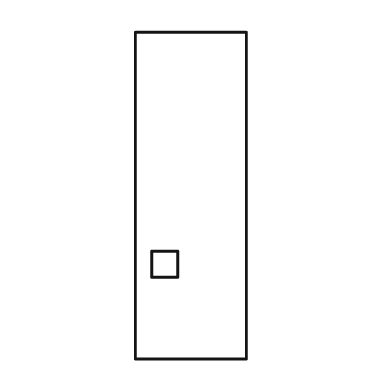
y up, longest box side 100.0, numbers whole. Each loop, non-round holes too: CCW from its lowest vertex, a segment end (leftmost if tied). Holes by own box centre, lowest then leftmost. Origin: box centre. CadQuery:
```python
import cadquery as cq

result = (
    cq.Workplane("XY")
    .moveTo(-17.0, -50.0)
    .lineTo(17.0, -50.0)
    .lineTo(17.0, 50.0)
    .lineTo(-17.0, 50.0)
    .close()
    .moveTo(-12.0, -25.0)
    .lineTo(-4.0, -25.0)
    .lineTo(-4.0, -17.0)
    .lineTo(-12.0, -17.0)
    .close()
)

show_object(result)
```